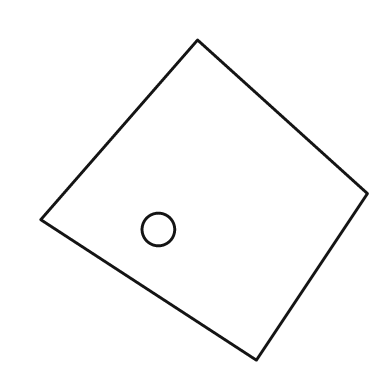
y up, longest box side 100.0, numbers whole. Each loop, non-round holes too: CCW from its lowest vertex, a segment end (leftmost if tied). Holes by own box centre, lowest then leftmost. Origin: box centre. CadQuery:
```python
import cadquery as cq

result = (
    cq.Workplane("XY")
    .moveTo(16.0, -49.0)
    .lineTo(50.0, 2.0)
    .lineTo(-2.0, 49.0)
    .lineTo(-50.0, -6.0)
    .close()
    .moveTo(-14.0, -9.0)
    .circle(5.0)
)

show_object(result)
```